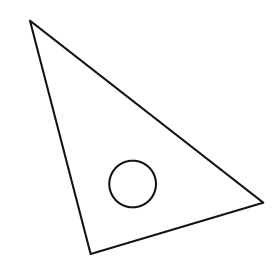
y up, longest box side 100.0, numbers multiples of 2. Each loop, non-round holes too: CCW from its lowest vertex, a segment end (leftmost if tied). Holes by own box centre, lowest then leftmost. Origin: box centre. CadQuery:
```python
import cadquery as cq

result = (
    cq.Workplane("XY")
    .moveTo(-24.0, -50.0)
    .lineTo(50.0, -28.0)
    .lineTo(-50.0, 50.0)
    .close()
    .moveTo(-6.0, -20.0)
    .circle(10.0)
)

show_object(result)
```